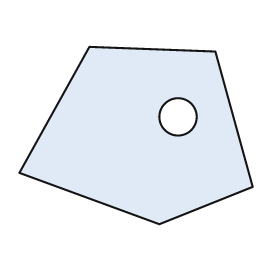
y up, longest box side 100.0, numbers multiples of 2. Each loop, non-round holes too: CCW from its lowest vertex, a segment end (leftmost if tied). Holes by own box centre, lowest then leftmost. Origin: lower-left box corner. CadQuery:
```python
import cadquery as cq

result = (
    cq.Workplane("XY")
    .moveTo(60.0, 0.0)
    .lineTo(100.0, 16.0)
    .lineTo(84.0, 74.0)
    .lineTo(30.0, 76.0)
    .lineTo(0.0, 22.0)
    .close()
    .moveTo(68.0, 46.0)
    .circle(8.0)
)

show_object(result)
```